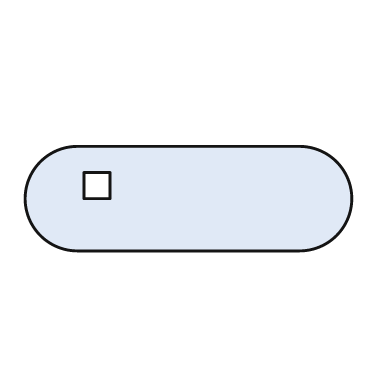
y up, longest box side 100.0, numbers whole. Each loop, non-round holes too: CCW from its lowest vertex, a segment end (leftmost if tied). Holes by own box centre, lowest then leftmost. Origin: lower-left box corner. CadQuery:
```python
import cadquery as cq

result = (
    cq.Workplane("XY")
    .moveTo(16.0, 0.0)
    .lineTo(84.0, 0.0)
    .threePointArc((100.0, 16.0), (84.0, 32.0))
    .lineTo(16.0, 32.0)
    .threePointArc((0.0, 16.0), (16.0, 0.0))
    .close()
    .moveTo(18.0, 16.0)
    .lineTo(26.0, 16.0)
    .lineTo(26.0, 24.0)
    .lineTo(18.0, 24.0)
    .close()
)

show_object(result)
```